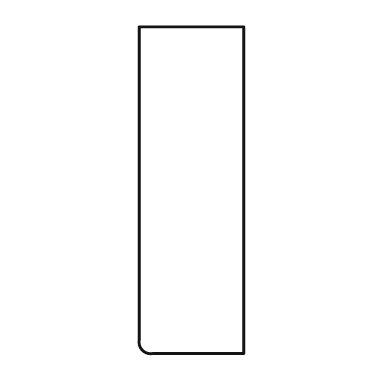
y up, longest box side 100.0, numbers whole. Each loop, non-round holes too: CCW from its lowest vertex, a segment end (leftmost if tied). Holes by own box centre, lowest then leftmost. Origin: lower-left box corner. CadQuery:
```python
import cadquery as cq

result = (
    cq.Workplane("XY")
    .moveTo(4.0, 0.0)
    .lineTo(32.0, 0.0)
    .lineTo(32.0, 100.0)
    .lineTo(0.0, 100.0)
    .lineTo(0.0, 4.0)
    .threePointArc((1.0, 1.0), (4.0, 0.0))
    .close()
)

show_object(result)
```